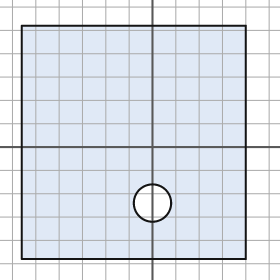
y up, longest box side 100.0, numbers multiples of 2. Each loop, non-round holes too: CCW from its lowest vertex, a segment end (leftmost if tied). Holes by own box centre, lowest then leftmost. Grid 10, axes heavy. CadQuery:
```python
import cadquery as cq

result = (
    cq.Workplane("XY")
    .moveTo(-56.0, -48.0)
    .lineTo(40.0, -48.0)
    .lineTo(40.0, 52.0)
    .lineTo(-56.0, 52.0)
    .close()
    .moveTo(0.0, -24.0)
    .circle(8.0)
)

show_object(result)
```